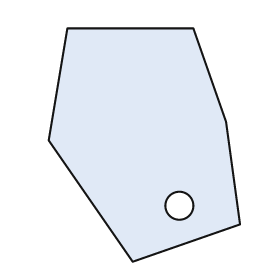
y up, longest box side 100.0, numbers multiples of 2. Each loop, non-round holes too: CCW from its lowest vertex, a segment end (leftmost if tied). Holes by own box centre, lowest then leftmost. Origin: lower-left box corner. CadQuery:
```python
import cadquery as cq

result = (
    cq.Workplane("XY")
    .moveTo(36.0, 0.0)
    .lineTo(82.0, 16.0)
    .lineTo(76.0, 60.0)
    .lineTo(62.0, 100.0)
    .lineTo(8.0, 100.0)
    .lineTo(0.0, 52.0)
    .close()
    .moveTo(56.0, 24.0)
    .circle(6.0)
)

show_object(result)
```